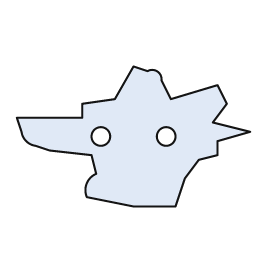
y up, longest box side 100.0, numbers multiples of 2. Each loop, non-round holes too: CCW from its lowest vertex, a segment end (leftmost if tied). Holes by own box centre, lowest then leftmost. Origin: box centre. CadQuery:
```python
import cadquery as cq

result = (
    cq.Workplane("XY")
    .moveTo(0.0, -30.0)
    .lineTo(18.0, -30.0)
    .lineTo(22.0, -18.0)
    .lineTo(28.0, -10.0)
    .lineTo(36.0, -8.0)
    .lineTo(36.0, -2.0)
    .lineTo(50.0, 2.0)
    .lineTo(34.0, 6.0)
    .lineTo(40.0, 14.0)
    .lineTo(36.0, 22.0)
    .lineTo(16.0, 16.0)
    .lineTo(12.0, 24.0)
    .threePointArc((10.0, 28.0), (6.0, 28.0))
    .lineTo(0.0, 30.0)
    .lineTo(-8.0, 16.0)
    .lineTo(-22.0, 14.0)
    .lineTo(-22.0, 8.0)
    .lineTo(-50.0, 8.0)
    .lineTo(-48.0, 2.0)
    .threePointArc((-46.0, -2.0), (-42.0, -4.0))
    .lineTo(-36.0, -6.0)
    .lineTo(-18.0, -8.0)
    .lineTo(-16.0, -16.0)
    .threePointArc((-20.0, -20.0), (-20.0, -26.0))
    .close()
    .moveTo(-14.0, 0.0)
    .circle(4.0)
    .moveTo(14.0, 0.0)
    .circle(4.0)
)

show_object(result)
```